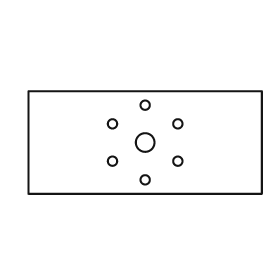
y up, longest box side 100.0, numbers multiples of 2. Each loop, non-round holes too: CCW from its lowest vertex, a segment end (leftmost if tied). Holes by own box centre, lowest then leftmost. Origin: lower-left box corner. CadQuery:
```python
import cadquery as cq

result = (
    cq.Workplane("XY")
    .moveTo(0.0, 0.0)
    .lineTo(100.0, 0.0)
    .lineTo(100.0, 44.0)
    .lineTo(0.0, 44.0)
    .close()
    .moveTo(50.0, 6.0)
    .circle(2.0)
    .moveTo(36.0, 14.0)
    .circle(2.0)
    .moveTo(64.0, 14.0)
    .circle(2.0)
    .moveTo(50.0, 22.0)
    .circle(4.0)
    .moveTo(36.0, 30.0)
    .circle(2.0)
    .moveTo(64.0, 30.0)
    .circle(2.0)
    .moveTo(50.0, 38.0)
    .circle(2.0)
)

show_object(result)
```